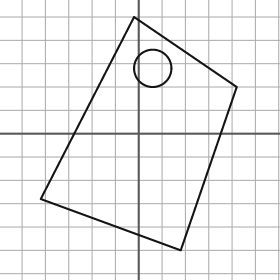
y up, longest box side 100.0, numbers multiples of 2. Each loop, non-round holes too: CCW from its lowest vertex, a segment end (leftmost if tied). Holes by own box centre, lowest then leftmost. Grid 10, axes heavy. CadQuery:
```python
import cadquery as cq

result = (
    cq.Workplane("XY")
    .moveTo(18.0, -50.0)
    .lineTo(42.0, 20.0)
    .lineTo(-2.0, 50.0)
    .lineTo(-42.0, -28.0)
    .close()
    .moveTo(6.0, 28.0)
    .circle(8.0)
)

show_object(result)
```